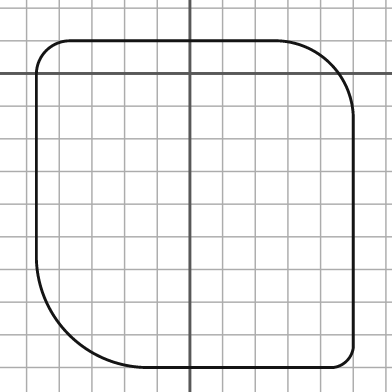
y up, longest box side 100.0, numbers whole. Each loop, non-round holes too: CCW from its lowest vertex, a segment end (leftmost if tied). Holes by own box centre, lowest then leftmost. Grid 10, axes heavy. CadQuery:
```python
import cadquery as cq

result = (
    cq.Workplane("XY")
    .moveTo(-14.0, -90.0)
    .lineTo(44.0, -90.0)
    .threePointArc((48.0, -88.0), (50.0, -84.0))
    .lineTo(50.0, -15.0)
    .threePointArc((43.0, 3.0), (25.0, 10.0))
    .lineTo(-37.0, 10.0)
    .threePointArc((-44.0, 7.0), (-47.0, 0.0))
    .lineTo(-47.0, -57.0)
    .threePointArc((-37.0, -80.0), (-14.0, -90.0))
    .close()
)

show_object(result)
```